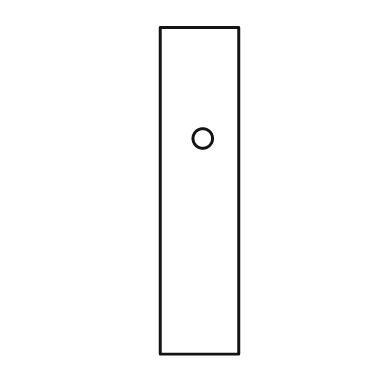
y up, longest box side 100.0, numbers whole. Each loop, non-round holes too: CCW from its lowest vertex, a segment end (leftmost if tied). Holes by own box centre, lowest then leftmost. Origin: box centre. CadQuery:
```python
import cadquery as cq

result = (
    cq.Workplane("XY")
    .moveTo(-12.0, -50.0)
    .lineTo(12.0, -50.0)
    .lineTo(12.0, 50.0)
    .lineTo(-12.0, 50.0)
    .close()
    .moveTo(1.0, 16.0)
    .circle(3.0)
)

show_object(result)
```